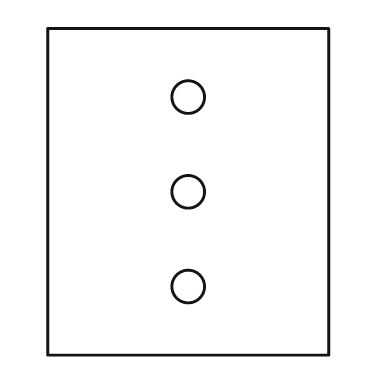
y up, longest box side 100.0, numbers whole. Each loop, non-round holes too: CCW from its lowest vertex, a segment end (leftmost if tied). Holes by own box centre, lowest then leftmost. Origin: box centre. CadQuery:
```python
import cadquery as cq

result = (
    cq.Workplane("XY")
    .moveTo(-43.0, -50.0)
    .lineTo(43.0, -50.0)
    .lineTo(43.0, 50.0)
    .lineTo(-43.0, 50.0)
    .close()
    .moveTo(0.0, -29.0)
    .circle(5.0)
    .moveTo(0.0, 0.0)
    .circle(5.0)
    .moveTo(0.0, 29.0)
    .circle(5.0)
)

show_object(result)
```